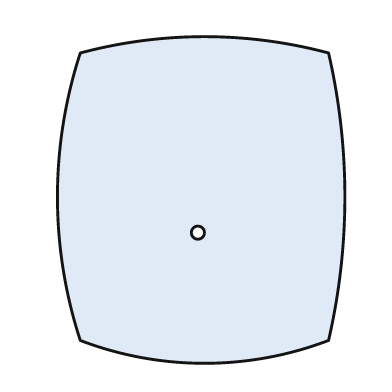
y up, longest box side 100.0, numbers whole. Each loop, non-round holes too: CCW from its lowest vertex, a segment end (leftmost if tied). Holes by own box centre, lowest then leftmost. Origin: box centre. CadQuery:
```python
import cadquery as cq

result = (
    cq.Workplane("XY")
    .moveTo(-37.0, -43.0)
    .threePointArc((1.0, -50.0), (39.0, -43.0))
    .threePointArc((44.0, 1.0), (39.0, 45.0))
    .threePointArc((1.0, 50.0), (-37.0, 45.0))
    .threePointArc((-44.0, 1.0), (-37.0, -43.0))
    .close()
    .moveTo(-1.0, -10.0)
    .circle(2.0)
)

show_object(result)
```